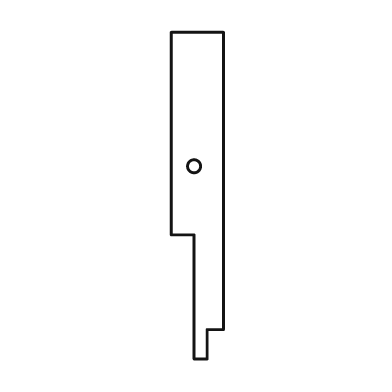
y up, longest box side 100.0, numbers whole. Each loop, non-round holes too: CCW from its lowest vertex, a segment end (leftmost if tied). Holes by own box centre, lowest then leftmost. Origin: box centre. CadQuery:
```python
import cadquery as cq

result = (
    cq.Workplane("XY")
    .moveTo(-1.0, -50.0)
    .lineTo(3.0, -50.0)
    .lineTo(3.0, -41.0)
    .lineTo(8.0, -41.0)
    .lineTo(8.0, 50.0)
    .lineTo(-8.0, 50.0)
    .lineTo(-8.0, -12.0)
    .lineTo(-1.0, -12.0)
    .close()
    .moveTo(-1.0, 9.0)
    .circle(2.0)
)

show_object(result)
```